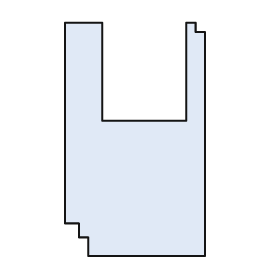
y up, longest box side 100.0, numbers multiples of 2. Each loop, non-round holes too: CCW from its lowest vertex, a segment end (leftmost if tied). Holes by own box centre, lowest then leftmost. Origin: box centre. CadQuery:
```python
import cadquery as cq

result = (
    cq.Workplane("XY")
    .moveTo(-20.0, -50.0)
    .lineTo(30.0, -50.0)
    .lineTo(30.0, 46.0)
    .lineTo(26.0, 46.0)
    .lineTo(26.0, 50.0)
    .lineTo(22.0, 50.0)
    .lineTo(22.0, 8.0)
    .lineTo(-14.0, 8.0)
    .lineTo(-14.0, 50.0)
    .lineTo(-30.0, 50.0)
    .lineTo(-30.0, -36.0)
    .lineTo(-24.0, -36.0)
    .lineTo(-24.0, -42.0)
    .lineTo(-20.0, -42.0)
    .close()
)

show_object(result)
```